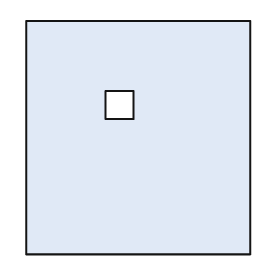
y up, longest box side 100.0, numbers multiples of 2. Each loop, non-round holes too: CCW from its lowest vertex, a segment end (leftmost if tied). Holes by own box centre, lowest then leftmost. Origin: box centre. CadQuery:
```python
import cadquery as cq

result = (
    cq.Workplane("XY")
    .moveTo(-48.0, -50.0)
    .lineTo(48.0, -50.0)
    .lineTo(48.0, 50.0)
    .lineTo(-48.0, 50.0)
    .close()
    .moveTo(-14.0, 8.0)
    .lineTo(-2.0, 8.0)
    .lineTo(-2.0, 20.0)
    .lineTo(-14.0, 20.0)
    .close()
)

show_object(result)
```